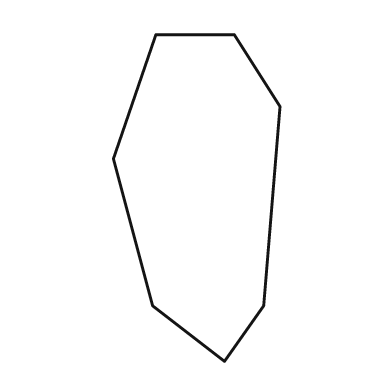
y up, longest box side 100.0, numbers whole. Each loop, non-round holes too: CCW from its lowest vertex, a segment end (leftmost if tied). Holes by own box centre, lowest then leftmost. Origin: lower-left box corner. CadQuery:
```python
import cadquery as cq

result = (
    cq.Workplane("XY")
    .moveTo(34.0, 0.0)
    .lineTo(46.0, 17.0)
    .lineTo(51.0, 78.0)
    .lineTo(37.0, 100.0)
    .lineTo(13.0, 100.0)
    .lineTo(0.0, 62.0)
    .lineTo(12.0, 17.0)
    .close()
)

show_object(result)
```